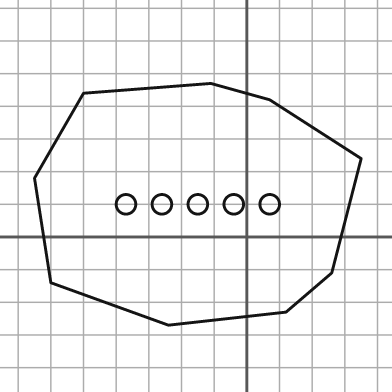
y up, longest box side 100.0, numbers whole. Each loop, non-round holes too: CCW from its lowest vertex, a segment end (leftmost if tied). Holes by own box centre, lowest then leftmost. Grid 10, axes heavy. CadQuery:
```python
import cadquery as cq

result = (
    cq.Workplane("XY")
    .moveTo(-24.0, -27.0)
    .lineTo(12.0, -23.0)
    .lineTo(26.0, -11.0)
    .lineTo(35.0, 24.0)
    .lineTo(7.0, 42.0)
    .lineTo(-11.0, 47.0)
    .lineTo(-50.0, 44.0)
    .lineTo(-65.0, 18.0)
    .lineTo(-60.0, -14.0)
    .close()
    .moveTo(-37.0, 10.0)
    .circle(3.0)
    .moveTo(-26.0, 10.0)
    .circle(3.0)
    .moveTo(-15.0, 10.0)
    .circle(3.0)
    .moveTo(-4.0, 10.0)
    .circle(3.0)
    .moveTo(7.0, 10.0)
    .circle(3.0)
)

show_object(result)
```